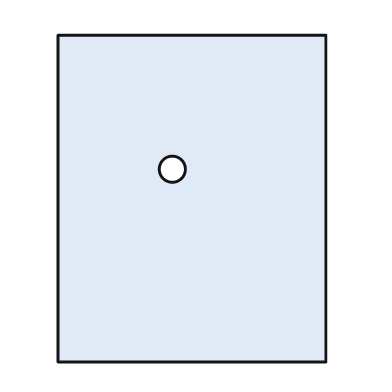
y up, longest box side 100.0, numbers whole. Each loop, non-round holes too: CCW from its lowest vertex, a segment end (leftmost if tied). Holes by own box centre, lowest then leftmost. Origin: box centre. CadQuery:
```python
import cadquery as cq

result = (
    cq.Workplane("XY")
    .moveTo(-41.0, -50.0)
    .lineTo(41.0, -50.0)
    .lineTo(41.0, 50.0)
    .lineTo(-41.0, 50.0)
    .close()
    .moveTo(-6.0, 9.0)
    .circle(4.0)
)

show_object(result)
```